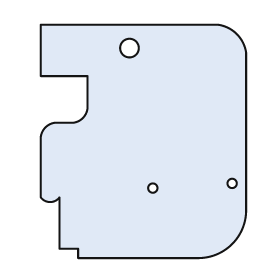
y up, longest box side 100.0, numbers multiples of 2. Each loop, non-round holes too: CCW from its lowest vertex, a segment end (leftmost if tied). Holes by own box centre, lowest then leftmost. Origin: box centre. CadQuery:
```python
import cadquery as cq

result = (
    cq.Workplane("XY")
    .moveTo(-28.0, -50.0)
    .lineTo(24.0, -50.0)
    .threePointArc((38.0, -44.0), (44.0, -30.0))
    .lineTo(44.0, 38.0)
    .threePointArc((40.0, 46.0), (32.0, 50.0))
    .lineTo(-44.0, 50.0)
    .lineTo(-44.0, 28.0)
    .lineTo(-24.0, 28.0)
    .lineTo(-24.0, 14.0)
    .threePointArc((-26.0, 10.0), (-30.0, 8.0))
    .lineTo(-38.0, 8.0)
    .threePointArc((-42.0, 6.0), (-44.0, 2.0))
    .lineTo(-44.0, -24.0)
    .threePointArc((-40.0, -26.0), (-36.0, -24.0))
    .lineTo(-36.0, -46.0)
    .lineTo(-28.0, -46.0)
    .close()
    .moveTo(4.0, -20.0)
    .circle(2.0)
    .moveTo(38.0, -18.0)
    .circle(2.0)
    .moveTo(-6.0, 40.0)
    .circle(4.0)
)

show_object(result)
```